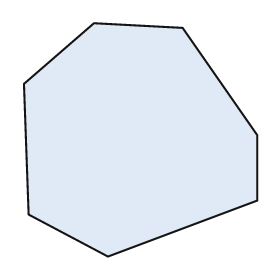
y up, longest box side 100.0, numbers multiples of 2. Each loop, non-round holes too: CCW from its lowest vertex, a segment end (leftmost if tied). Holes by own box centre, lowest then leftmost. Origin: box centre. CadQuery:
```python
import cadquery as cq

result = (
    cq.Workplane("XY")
    .moveTo(-14.0, -50.0)
    .lineTo(50.0, -26.0)
    .lineTo(50.0, 2.0)
    .lineTo(18.0, 48.0)
    .lineTo(-20.0, 50.0)
    .lineTo(-50.0, 24.0)
    .lineTo(-48.0, -32.0)
    .close()
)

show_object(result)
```